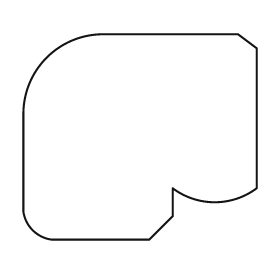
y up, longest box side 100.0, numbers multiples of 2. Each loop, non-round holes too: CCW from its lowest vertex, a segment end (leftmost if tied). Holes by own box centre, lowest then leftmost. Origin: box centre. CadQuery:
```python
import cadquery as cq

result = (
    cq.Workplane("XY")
    .moveTo(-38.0, -44.0)
    .lineTo(4.0, -44.0)
    .lineTo(14.0, -34.0)
    .lineTo(14.0, -22.0)
    .threePointArc((32.0, -28.0), (50.0, -22.0))
    .lineTo(50.0, 38.0)
    .lineTo(42.0, 44.0)
    .lineTo(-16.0, 44.0)
    .threePointArc((-40.0, 34.0), (-50.0, 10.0))
    .lineTo(-50.0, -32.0)
    .threePointArc((-46.0, -40.0), (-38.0, -44.0))
    .close()
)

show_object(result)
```